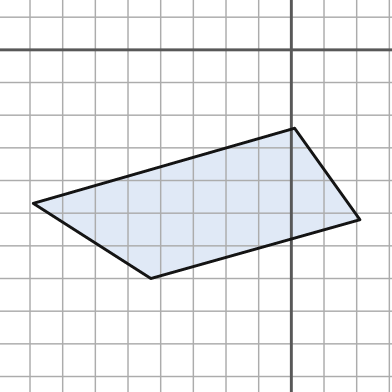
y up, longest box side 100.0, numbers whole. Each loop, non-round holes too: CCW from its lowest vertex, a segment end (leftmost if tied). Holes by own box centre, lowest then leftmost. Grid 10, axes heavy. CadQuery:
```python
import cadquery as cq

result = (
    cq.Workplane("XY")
    .moveTo(-43.0, -70.0)
    .lineTo(21.0, -52.0)
    .lineTo(1.0, -24.0)
    .lineTo(-79.0, -47.0)
    .close()
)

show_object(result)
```